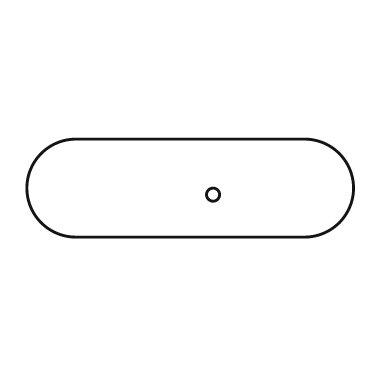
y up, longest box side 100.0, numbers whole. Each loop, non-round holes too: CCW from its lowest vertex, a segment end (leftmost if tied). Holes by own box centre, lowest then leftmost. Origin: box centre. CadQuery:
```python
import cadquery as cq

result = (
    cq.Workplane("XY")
    .moveTo(-35.0, -15.0)
    .lineTo(35.0, -15.0)
    .threePointArc((50.0, 0.0), (35.0, 15.0))
    .lineTo(-35.0, 15.0)
    .threePointArc((-50.0, 0.0), (-35.0, -15.0))
    .close()
    .moveTo(7.0, -2.0)
    .circle(2.0)
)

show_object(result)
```